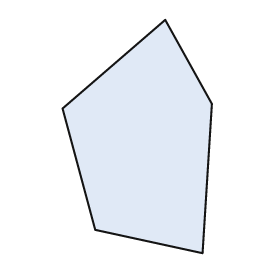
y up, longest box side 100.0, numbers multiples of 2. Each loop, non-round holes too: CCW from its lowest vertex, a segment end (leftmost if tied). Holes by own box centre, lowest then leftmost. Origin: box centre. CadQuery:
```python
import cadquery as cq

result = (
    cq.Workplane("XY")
    .moveTo(28.0, -50.0)
    .lineTo(32.0, 14.0)
    .lineTo(12.0, 50.0)
    .lineTo(-32.0, 12.0)
    .lineTo(-18.0, -40.0)
    .close()
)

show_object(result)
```